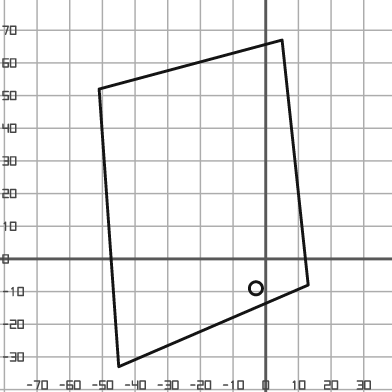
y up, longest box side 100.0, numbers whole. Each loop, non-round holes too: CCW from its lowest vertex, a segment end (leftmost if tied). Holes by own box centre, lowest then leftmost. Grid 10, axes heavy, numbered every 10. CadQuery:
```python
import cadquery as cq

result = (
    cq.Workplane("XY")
    .moveTo(-45.0, -33.0)
    .lineTo(13.0, -8.0)
    .lineTo(5.0, 67.0)
    .lineTo(-51.0, 52.0)
    .close()
    .moveTo(-3.0, -9.0)
    .circle(2.0)
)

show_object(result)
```